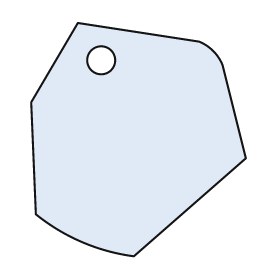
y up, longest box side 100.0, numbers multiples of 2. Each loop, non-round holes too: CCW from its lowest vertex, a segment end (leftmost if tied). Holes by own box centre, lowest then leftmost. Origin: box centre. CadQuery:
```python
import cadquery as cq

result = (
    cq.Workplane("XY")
    .moveTo(-2.0, -50.0)
    .lineTo(46.0, -8.0)
    .lineTo(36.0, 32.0)
    .threePointArc((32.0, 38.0), (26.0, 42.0))
    .lineTo(-26.0, 50.0)
    .lineTo(-46.0, 16.0)
    .lineTo(-44.0, -32.0)
    .threePointArc((-24.0, -44.0), (-2.0, -50.0))
    .close()
    .moveTo(-16.0, 34.0)
    .circle(6.0)
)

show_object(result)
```